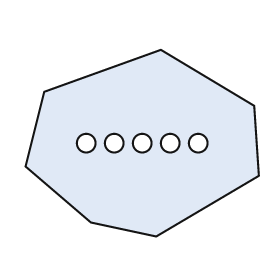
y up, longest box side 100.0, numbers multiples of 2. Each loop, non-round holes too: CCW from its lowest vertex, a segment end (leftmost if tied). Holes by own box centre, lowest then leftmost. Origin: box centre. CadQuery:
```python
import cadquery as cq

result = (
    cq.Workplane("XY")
    .moveTo(6.0, -40.0)
    .lineTo(50.0, -14.0)
    .lineTo(48.0, 16.0)
    .lineTo(8.0, 40.0)
    .lineTo(-42.0, 22.0)
    .lineTo(-50.0, -10.0)
    .lineTo(-22.0, -34.0)
    .close()
    .moveTo(-24.0, 0.0)
    .circle(4.0)
    .moveTo(-12.0, 0.0)
    .circle(4.0)
    .moveTo(0.0, 0.0)
    .circle(4.0)
    .moveTo(12.0, 0.0)
    .circle(4.0)
    .moveTo(24.0, 0.0)
    .circle(4.0)
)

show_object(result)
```